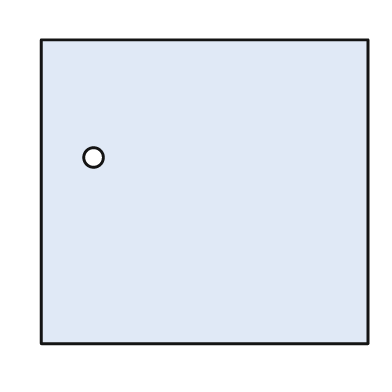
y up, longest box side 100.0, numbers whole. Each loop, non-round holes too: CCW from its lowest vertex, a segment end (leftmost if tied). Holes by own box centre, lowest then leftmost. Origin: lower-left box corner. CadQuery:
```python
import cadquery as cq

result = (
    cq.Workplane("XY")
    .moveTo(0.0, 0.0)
    .lineTo(100.0, 0.0)
    .lineTo(100.0, 93.0)
    .lineTo(0.0, 93.0)
    .close()
    .moveTo(16.0, 57.0)
    .circle(3.0)
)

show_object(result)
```